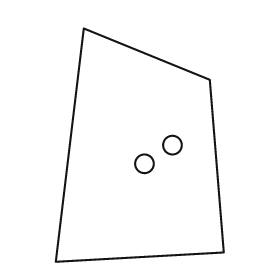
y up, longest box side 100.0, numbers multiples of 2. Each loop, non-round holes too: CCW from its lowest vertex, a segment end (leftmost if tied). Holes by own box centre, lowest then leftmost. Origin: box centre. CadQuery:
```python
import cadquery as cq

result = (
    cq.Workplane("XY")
    .moveTo(-36.0, -50.0)
    .lineTo(36.0, -46.0)
    .lineTo(30.0, 28.0)
    .lineTo(-24.0, 50.0)
    .close()
    .moveTo(2.0, -8.0)
    .circle(4.0)
    .moveTo(14.0, 0.0)
    .circle(4.0)
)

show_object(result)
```